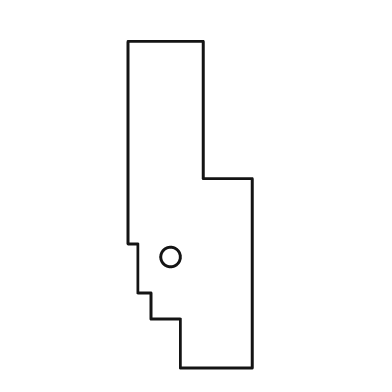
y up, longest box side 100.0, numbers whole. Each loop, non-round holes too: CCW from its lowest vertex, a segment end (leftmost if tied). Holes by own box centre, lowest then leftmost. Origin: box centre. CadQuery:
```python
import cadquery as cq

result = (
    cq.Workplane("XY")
    .moveTo(-3.0, -50.0)
    .lineTo(19.0, -50.0)
    .lineTo(19.0, 8.0)
    .lineTo(4.0, 8.0)
    .lineTo(4.0, 50.0)
    .lineTo(-19.0, 50.0)
    .lineTo(-19.0, -12.0)
    .lineTo(-16.0, -12.0)
    .lineTo(-16.0, -27.0)
    .lineTo(-12.0, -27.0)
    .lineTo(-12.0, -35.0)
    .lineTo(-3.0, -35.0)
    .close()
    .moveTo(-6.0, -16.0)
    .circle(3.0)
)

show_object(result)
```